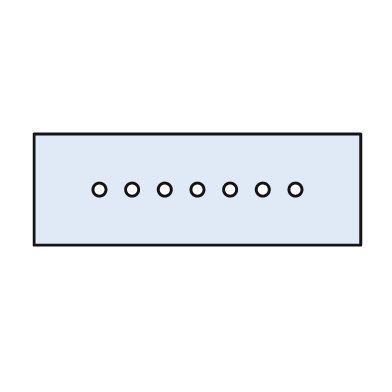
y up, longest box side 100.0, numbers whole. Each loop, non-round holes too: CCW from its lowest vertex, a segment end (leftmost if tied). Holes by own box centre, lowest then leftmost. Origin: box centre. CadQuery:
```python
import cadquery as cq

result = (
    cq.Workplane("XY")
    .moveTo(-50.0, -17.0)
    .lineTo(50.0, -17.0)
    .lineTo(50.0, 17.0)
    .lineTo(-50.0, 17.0)
    .close()
    .moveTo(-30.0, 0.0)
    .circle(2.0)
    .moveTo(-20.0, 0.0)
    .circle(2.0)
    .moveTo(-10.0, 0.0)
    .circle(2.0)
    .moveTo(0.0, 0.0)
    .circle(2.0)
    .moveTo(10.0, 0.0)
    .circle(2.0)
    .moveTo(20.0, 0.0)
    .circle(2.0)
    .moveTo(30.0, 0.0)
    .circle(2.0)
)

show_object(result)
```